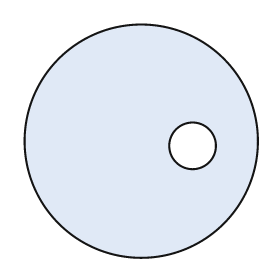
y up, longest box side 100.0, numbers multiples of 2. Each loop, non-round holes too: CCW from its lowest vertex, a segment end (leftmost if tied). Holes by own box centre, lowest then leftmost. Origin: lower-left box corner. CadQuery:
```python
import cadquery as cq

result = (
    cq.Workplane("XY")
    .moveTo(50.0, 50.0)
    .circle(50.0)
    .moveTo(72.0, 48.0)
    .circle(10.0)
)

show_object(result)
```